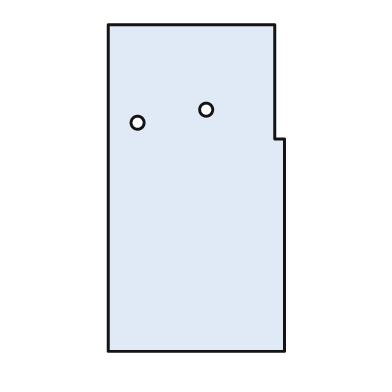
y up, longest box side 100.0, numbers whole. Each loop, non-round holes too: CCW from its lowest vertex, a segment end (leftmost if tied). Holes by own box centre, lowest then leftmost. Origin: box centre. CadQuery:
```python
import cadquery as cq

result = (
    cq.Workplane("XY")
    .moveTo(-27.0, -50.0)
    .lineTo(27.0, -50.0)
    .lineTo(27.0, 15.0)
    .lineTo(24.0, 15.0)
    .lineTo(24.0, 50.0)
    .lineTo(-27.0, 50.0)
    .close()
    .moveTo(-18.0, 20.0)
    .circle(2.0)
    .moveTo(3.0, 24.0)
    .circle(2.0)
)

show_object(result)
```